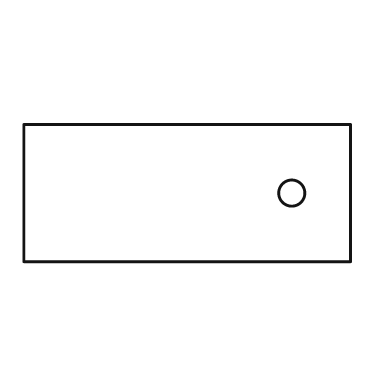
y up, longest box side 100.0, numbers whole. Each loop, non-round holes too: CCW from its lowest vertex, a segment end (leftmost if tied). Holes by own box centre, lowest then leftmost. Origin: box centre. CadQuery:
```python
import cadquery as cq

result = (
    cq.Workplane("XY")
    .moveTo(-50.0, -21.0)
    .lineTo(50.0, -21.0)
    .lineTo(50.0, 21.0)
    .lineTo(-50.0, 21.0)
    .close()
    .moveTo(32.0, 0.0)
    .circle(4.0)
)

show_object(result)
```